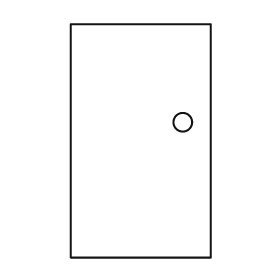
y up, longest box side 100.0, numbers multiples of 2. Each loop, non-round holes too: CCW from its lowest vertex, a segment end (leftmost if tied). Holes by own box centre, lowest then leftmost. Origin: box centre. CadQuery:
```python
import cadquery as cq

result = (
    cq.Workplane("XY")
    .moveTo(-30.0, -50.0)
    .lineTo(30.0, -50.0)
    .lineTo(30.0, 50.0)
    .lineTo(-30.0, 50.0)
    .close()
    .moveTo(18.0, 8.0)
    .circle(4.0)
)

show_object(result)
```